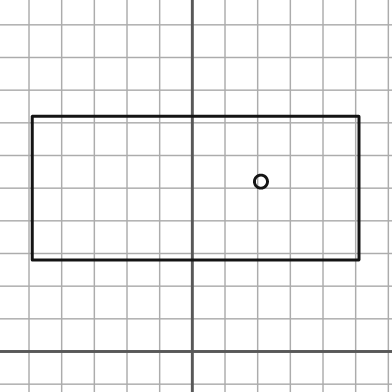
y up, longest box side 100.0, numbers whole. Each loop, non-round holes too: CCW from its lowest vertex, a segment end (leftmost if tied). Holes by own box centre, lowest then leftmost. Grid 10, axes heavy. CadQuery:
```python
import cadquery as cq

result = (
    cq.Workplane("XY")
    .moveTo(-49.0, 28.0)
    .lineTo(51.0, 28.0)
    .lineTo(51.0, 72.0)
    .lineTo(-49.0, 72.0)
    .close()
    .moveTo(21.0, 52.0)
    .circle(2.0)
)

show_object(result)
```